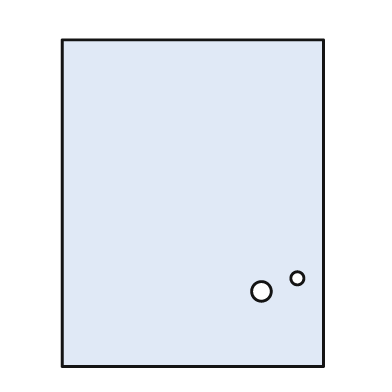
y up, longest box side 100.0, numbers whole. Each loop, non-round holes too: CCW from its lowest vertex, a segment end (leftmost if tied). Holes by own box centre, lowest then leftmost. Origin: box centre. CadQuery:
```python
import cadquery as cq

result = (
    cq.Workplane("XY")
    .moveTo(-40.0, -50.0)
    .lineTo(40.0, -50.0)
    .lineTo(40.0, 50.0)
    .lineTo(-40.0, 50.0)
    .close()
    .moveTo(21.0, -27.0)
    .circle(3.0)
    .moveTo(32.0, -23.0)
    .circle(2.0)
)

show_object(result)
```